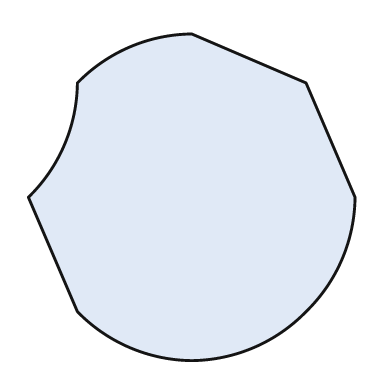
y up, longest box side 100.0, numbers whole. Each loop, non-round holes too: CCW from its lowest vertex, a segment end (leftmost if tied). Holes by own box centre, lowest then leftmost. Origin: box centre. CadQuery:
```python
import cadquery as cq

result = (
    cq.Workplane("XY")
    .moveTo(0.0, -50.0)
    .threePointArc((19.0, -46.0), (35.0, -35.0))
    .threePointArc((46.0, -19.0), (50.0, 0.0))
    .lineTo(35.0, 35.0)
    .lineTo(0.0, 50.0)
    .threePointArc((-19.0, 46.0), (-35.0, 35.0))
    .threePointArc((-39.0, 16.0), (-50.0, 0.0))
    .lineTo(-35.0, -35.0)
    .threePointArc((-19.0, -46.0), (0.0, -50.0))
    .close()
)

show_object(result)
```